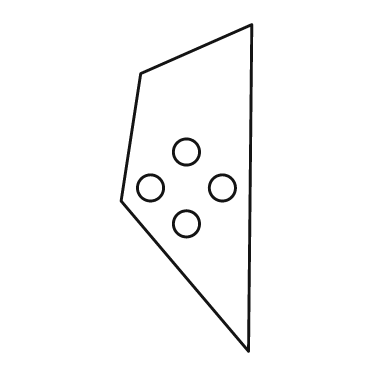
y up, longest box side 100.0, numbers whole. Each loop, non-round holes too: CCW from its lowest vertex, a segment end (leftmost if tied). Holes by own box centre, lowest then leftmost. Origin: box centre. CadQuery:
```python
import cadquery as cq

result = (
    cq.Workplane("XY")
    .moveTo(19.0, -50.0)
    .lineTo(20.0, 50.0)
    .lineTo(-14.0, 35.0)
    .lineTo(-20.0, -4.0)
    .close()
    .moveTo(0.0, -11.0)
    .circle(4.0)
    .moveTo(-11.0, 0.0)
    .circle(4.0)
    .moveTo(11.0, 0.0)
    .circle(4.0)
    .moveTo(0.0, 11.0)
    .circle(4.0)
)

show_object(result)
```